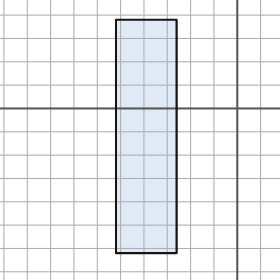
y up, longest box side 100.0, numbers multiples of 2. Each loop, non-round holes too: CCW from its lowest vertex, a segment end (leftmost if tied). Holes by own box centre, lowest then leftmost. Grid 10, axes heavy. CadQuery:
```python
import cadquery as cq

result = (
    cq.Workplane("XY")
    .moveTo(-52.0, -62.0)
    .lineTo(-26.0, -62.0)
    .lineTo(-26.0, 38.0)
    .lineTo(-52.0, 38.0)
    .close()
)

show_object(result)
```